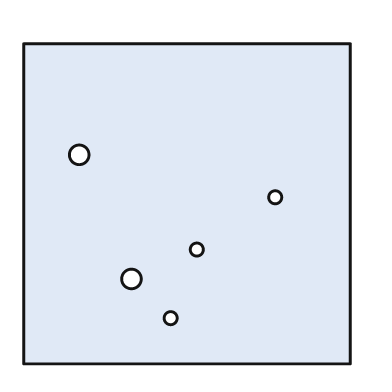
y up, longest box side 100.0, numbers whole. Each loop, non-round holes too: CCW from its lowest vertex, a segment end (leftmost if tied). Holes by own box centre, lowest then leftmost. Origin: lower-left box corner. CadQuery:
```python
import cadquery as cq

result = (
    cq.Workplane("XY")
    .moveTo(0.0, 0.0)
    .lineTo(100.0, 0.0)
    .lineTo(100.0, 98.0)
    .lineTo(0.0, 98.0)
    .close()
    .moveTo(45.0, 14.0)
    .circle(2.0)
    .moveTo(33.0, 26.0)
    .circle(3.0)
    .moveTo(53.0, 35.0)
    .circle(2.0)
    .moveTo(77.0, 51.0)
    .circle(2.0)
    .moveTo(17.0, 64.0)
    .circle(3.0)
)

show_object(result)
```